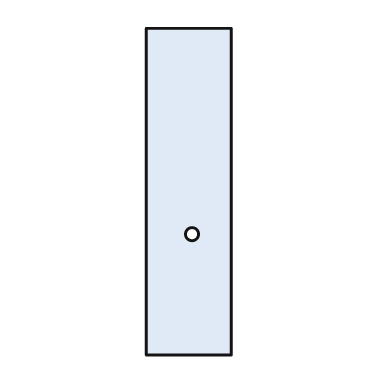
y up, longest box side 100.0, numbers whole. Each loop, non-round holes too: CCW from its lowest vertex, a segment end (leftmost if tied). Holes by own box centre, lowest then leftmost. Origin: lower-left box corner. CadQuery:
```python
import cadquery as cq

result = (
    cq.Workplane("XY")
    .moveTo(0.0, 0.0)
    .lineTo(26.0, 0.0)
    .lineTo(26.0, 100.0)
    .lineTo(0.0, 100.0)
    .close()
    .moveTo(14.0, 37.0)
    .circle(2.0)
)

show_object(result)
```